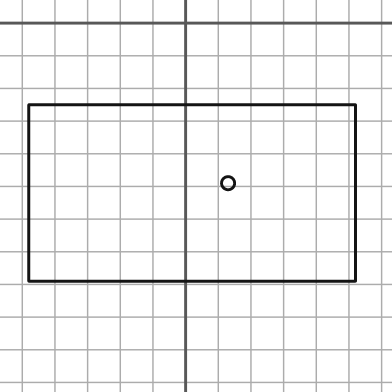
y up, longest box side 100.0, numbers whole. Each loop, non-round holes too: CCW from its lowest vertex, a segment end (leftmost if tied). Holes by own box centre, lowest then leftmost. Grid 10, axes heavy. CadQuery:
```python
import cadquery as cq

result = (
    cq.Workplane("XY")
    .moveTo(-48.0, -79.0)
    .lineTo(52.0, -79.0)
    .lineTo(52.0, -25.0)
    .lineTo(-48.0, -25.0)
    .close()
    .moveTo(13.0, -49.0)
    .circle(2.0)
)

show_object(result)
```